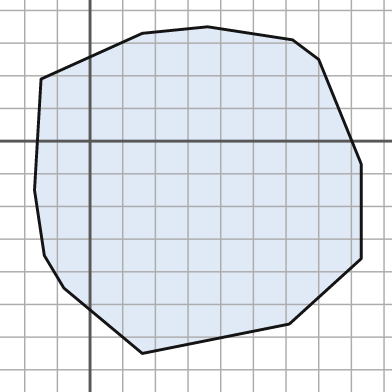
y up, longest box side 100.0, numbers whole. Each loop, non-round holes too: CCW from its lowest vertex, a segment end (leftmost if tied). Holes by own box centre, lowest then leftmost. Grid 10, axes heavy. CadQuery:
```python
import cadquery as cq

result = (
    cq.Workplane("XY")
    .moveTo(16.0, -65.0)
    .lineTo(61.0, -56.0)
    .lineTo(83.0, -36.0)
    .lineTo(83.0, -7.0)
    .lineTo(70.0, 25.0)
    .lineTo(62.0, 31.0)
    .lineTo(36.0, 35.0)
    .lineTo(16.0, 33.0)
    .lineTo(-15.0, 19.0)
    .lineTo(-17.0, -15.0)
    .lineTo(-14.0, -35.0)
    .lineTo(-8.0, -45.0)
    .close()
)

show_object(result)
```